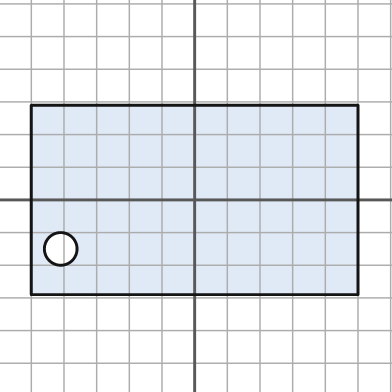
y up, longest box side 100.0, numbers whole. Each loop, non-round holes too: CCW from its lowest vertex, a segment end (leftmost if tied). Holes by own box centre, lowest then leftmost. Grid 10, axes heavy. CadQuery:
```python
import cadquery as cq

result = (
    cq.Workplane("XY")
    .moveTo(-50.0, -29.0)
    .lineTo(50.0, -29.0)
    .lineTo(50.0, 29.0)
    .lineTo(-50.0, 29.0)
    .close()
    .moveTo(-41.0, -15.0)
    .circle(5.0)
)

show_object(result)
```